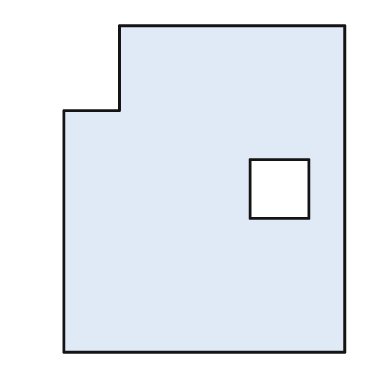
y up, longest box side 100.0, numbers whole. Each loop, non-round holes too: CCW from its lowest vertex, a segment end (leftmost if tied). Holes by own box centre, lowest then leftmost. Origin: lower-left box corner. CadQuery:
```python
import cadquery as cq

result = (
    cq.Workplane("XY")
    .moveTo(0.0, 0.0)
    .lineTo(86.0, 0.0)
    .lineTo(86.0, 100.0)
    .lineTo(17.0, 100.0)
    .lineTo(17.0, 74.0)
    .lineTo(0.0, 74.0)
    .close()
    .moveTo(57.0, 41.0)
    .lineTo(75.0, 41.0)
    .lineTo(75.0, 59.0)
    .lineTo(57.0, 59.0)
    .close()
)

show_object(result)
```